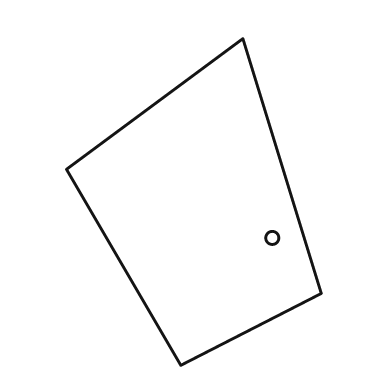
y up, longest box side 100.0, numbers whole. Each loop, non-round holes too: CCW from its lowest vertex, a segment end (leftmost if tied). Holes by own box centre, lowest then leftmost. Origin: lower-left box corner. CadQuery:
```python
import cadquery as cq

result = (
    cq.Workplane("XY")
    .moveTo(35.0, 0.0)
    .lineTo(78.0, 22.0)
    .lineTo(54.0, 100.0)
    .lineTo(0.0, 60.0)
    .close()
    .moveTo(63.0, 39.0)
    .circle(2.0)
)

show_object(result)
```